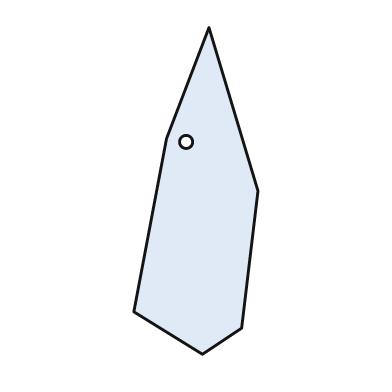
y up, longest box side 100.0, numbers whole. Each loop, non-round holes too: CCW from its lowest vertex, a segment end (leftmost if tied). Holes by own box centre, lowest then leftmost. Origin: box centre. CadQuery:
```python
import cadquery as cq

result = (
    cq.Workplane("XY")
    .moveTo(2.0, -50.0)
    .lineTo(14.0, -42.0)
    .lineTo(19.0, 0.0)
    .lineTo(4.0, 50.0)
    .lineTo(-9.0, 16.0)
    .lineTo(-19.0, -37.0)
    .close()
    .moveTo(-3.0, 15.0)
    .circle(2.0)
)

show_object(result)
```